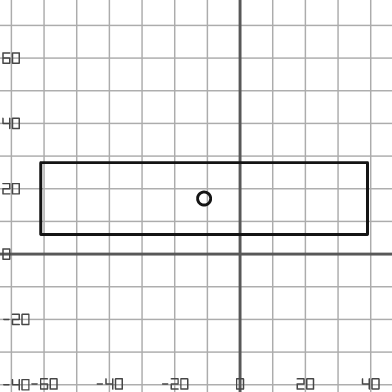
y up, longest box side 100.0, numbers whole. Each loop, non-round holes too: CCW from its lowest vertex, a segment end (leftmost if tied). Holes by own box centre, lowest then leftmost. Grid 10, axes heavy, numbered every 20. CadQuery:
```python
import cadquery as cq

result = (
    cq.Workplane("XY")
    .moveTo(-61.0, 6.0)
    .lineTo(39.0, 6.0)
    .lineTo(39.0, 28.0)
    .lineTo(-61.0, 28.0)
    .close()
    .moveTo(-11.0, 17.0)
    .circle(2.0)
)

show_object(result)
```